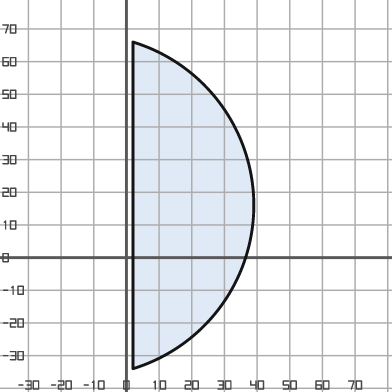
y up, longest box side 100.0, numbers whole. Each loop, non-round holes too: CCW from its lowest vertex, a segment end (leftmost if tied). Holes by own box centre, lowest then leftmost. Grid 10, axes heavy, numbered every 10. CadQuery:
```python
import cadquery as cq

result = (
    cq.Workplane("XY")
    .moveTo(2.0, -34.0)
    .threePointArc((39.0, 16.0), (2.0, 66.0))
    .close()
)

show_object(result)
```